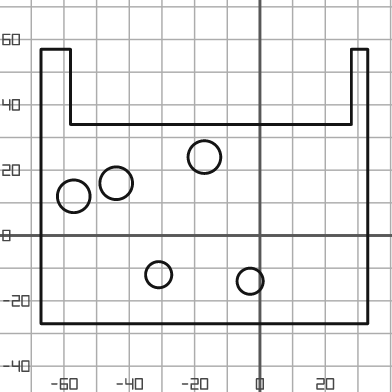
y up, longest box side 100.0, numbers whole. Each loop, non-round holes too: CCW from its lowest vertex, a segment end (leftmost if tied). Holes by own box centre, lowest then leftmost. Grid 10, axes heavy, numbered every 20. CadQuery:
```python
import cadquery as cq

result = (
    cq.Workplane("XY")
    .moveTo(-67.0, -27.0)
    .lineTo(33.0, -27.0)
    .lineTo(33.0, 57.0)
    .lineTo(28.0, 57.0)
    .lineTo(28.0, 34.0)
    .lineTo(-58.0, 34.0)
    .lineTo(-58.0, 57.0)
    .lineTo(-67.0, 57.0)
    .close()
    .moveTo(-3.0, -14.0)
    .circle(4.0)
    .moveTo(-31.0, -12.0)
    .circle(4.0)
    .moveTo(-57.0, 12.0)
    .circle(5.0)
    .moveTo(-44.0, 16.0)
    .circle(5.0)
    .moveTo(-17.0, 24.0)
    .circle(5.0)
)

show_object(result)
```